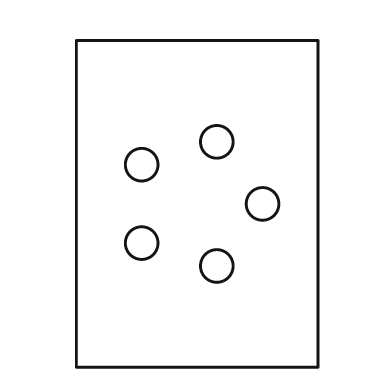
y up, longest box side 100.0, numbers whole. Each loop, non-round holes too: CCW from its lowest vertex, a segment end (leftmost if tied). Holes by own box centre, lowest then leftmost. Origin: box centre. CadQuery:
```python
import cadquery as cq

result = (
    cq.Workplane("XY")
    .moveTo(-37.0, -50.0)
    .lineTo(37.0, -50.0)
    .lineTo(37.0, 50.0)
    .lineTo(-37.0, 50.0)
    .close()
    .moveTo(6.0, -19.0)
    .circle(5.0)
    .moveTo(-17.0, -12.0)
    .circle(5.0)
    .moveTo(20.0, 0.0)
    .circle(5.0)
    .moveTo(-17.0, 12.0)
    .circle(5.0)
    .moveTo(6.0, 19.0)
    .circle(5.0)
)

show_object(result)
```